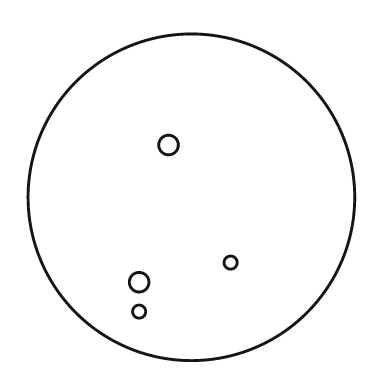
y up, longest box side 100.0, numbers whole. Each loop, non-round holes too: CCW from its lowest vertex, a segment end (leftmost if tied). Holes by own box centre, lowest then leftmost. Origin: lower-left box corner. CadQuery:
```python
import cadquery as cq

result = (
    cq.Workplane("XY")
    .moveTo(50.0, 50.0)
    .circle(50.0)
    .moveTo(34.0, 15.0)
    .circle(2.0)
    .moveTo(34.0, 24.0)
    .circle(3.0)
    .moveTo(62.0, 30.0)
    .circle(2.0)
    .moveTo(43.0, 66.0)
    .circle(3.0)
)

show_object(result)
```